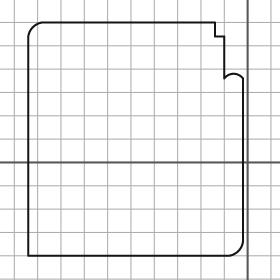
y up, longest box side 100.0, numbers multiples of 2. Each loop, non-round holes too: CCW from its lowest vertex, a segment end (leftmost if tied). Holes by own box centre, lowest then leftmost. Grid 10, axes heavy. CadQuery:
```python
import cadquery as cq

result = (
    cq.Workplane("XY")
    .moveTo(-94.0, -40.0)
    .lineTo(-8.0, -40.0)
    .threePointArc((-4.0, -38.0), (-2.0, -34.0))
    .lineTo(-2.0, 36.0)
    .threePointArc((-6.0, 38.0), (-10.0, 36.0))
    .lineTo(-10.0, 54.0)
    .lineTo(-14.0, 54.0)
    .lineTo(-14.0, 60.0)
    .lineTo(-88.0, 60.0)
    .threePointArc((-92.0, 58.0), (-94.0, 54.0))
    .close()
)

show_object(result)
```